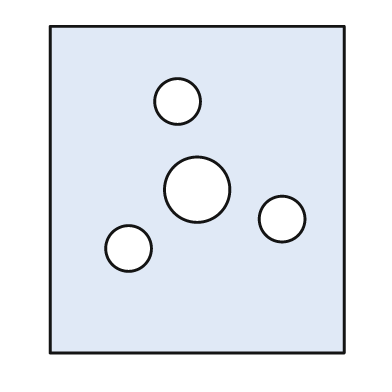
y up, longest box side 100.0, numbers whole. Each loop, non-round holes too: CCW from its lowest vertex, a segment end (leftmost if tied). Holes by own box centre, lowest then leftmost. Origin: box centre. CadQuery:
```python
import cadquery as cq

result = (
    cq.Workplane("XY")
    .moveTo(-45.0, -50.0)
    .lineTo(45.0, -50.0)
    .lineTo(45.0, 50.0)
    .lineTo(-45.0, 50.0)
    .close()
    .moveTo(-21.0, -18.0)
    .circle(7.0)
    .moveTo(26.0, -9.0)
    .circle(7.0)
    .moveTo(0.0, 0.0)
    .circle(10.0)
    .moveTo(-6.0, 27.0)
    .circle(7.0)
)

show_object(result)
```